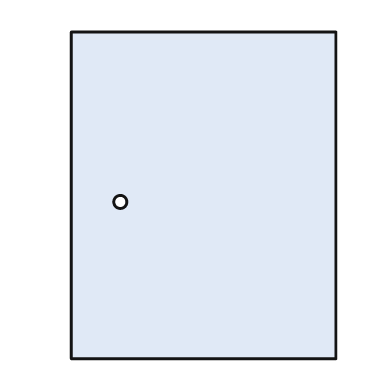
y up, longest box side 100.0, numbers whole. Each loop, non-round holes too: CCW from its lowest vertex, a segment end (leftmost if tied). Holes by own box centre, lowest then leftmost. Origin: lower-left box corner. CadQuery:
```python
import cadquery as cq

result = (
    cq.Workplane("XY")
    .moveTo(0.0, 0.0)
    .lineTo(81.0, 0.0)
    .lineTo(81.0, 100.0)
    .lineTo(0.0, 100.0)
    .close()
    .moveTo(15.0, 48.0)
    .circle(2.0)
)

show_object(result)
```